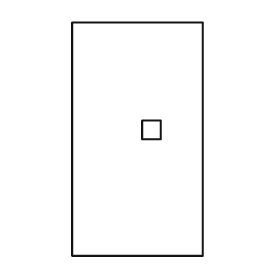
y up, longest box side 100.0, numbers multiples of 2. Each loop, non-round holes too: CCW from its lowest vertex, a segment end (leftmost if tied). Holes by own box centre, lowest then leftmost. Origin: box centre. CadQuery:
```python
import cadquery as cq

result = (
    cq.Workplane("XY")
    .moveTo(-28.0, -50.0)
    .lineTo(28.0, -50.0)
    .lineTo(28.0, 50.0)
    .lineTo(-28.0, 50.0)
    .close()
    .moveTo(2.0, 0.0)
    .lineTo(10.0, 0.0)
    .lineTo(10.0, 8.0)
    .lineTo(2.0, 8.0)
    .close()
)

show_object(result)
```